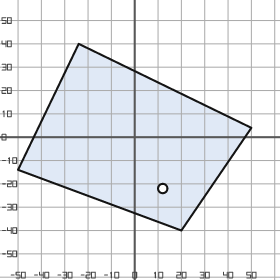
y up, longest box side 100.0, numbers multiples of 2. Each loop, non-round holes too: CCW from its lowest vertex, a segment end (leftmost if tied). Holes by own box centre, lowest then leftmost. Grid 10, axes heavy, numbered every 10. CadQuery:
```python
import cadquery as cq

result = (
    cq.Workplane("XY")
    .moveTo(20.0, -40.0)
    .lineTo(50.0, 4.0)
    .lineTo(-24.0, 40.0)
    .lineTo(-50.0, -14.0)
    .close()
    .moveTo(12.0, -22.0)
    .circle(2.0)
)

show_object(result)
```